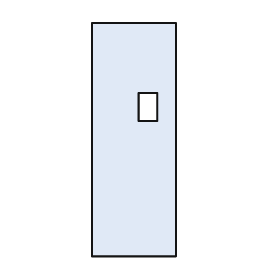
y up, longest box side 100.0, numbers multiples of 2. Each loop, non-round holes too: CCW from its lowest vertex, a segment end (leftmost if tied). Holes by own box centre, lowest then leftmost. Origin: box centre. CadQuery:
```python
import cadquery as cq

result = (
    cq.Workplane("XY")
    .moveTo(-18.0, -50.0)
    .lineTo(18.0, -50.0)
    .lineTo(18.0, 50.0)
    .lineTo(-18.0, 50.0)
    .close()
    .moveTo(2.0, 8.0)
    .lineTo(10.0, 8.0)
    .lineTo(10.0, 20.0)
    .lineTo(2.0, 20.0)
    .close()
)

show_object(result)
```